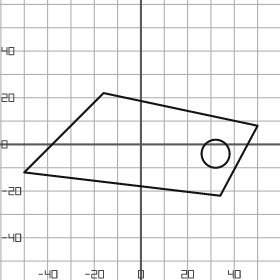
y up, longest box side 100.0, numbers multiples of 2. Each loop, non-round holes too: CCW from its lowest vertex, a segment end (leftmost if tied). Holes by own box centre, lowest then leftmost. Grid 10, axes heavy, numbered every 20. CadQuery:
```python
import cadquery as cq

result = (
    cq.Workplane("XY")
    .moveTo(34.0, -22.0)
    .lineTo(50.0, 8.0)
    .lineTo(-16.0, 22.0)
    .lineTo(-50.0, -12.0)
    .close()
    .moveTo(32.0, -4.0)
    .circle(6.0)
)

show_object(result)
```